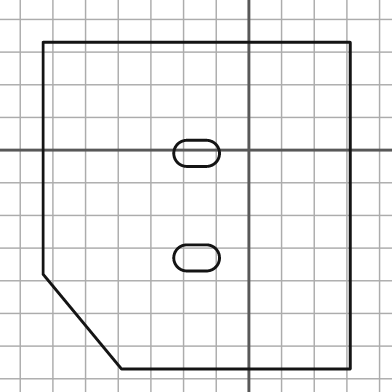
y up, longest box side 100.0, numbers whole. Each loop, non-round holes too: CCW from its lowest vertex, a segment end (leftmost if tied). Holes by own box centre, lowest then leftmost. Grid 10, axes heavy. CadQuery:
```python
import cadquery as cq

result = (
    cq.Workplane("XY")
    .moveTo(-39.0, -67.0)
    .lineTo(31.0, -67.0)
    .lineTo(31.0, 33.0)
    .lineTo(-63.0, 33.0)
    .lineTo(-63.0, -38.0)
    .close()
    .moveTo(-19.0, -37.0)
    .lineTo(-13.0, -37.0)
    .threePointArc((-9.0, -33.0), (-13.0, -29.0))
    .lineTo(-19.0, -29.0)
    .threePointArc((-23.0, -33.0), (-19.0, -37.0))
    .close()
    .moveTo(-19.0, -5.0)
    .lineTo(-13.0, -5.0)
    .threePointArc((-9.0, -1.0), (-13.0, 3.0))
    .lineTo(-19.0, 3.0)
    .threePointArc((-23.0, -1.0), (-19.0, -5.0))
    .close()
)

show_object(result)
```